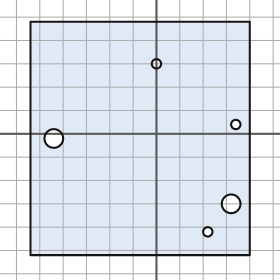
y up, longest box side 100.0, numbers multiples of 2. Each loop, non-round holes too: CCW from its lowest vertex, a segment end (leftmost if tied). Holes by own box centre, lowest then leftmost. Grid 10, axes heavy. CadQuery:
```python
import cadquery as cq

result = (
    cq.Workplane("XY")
    .moveTo(-54.0, -52.0)
    .lineTo(40.0, -52.0)
    .lineTo(40.0, 48.0)
    .lineTo(-54.0, 48.0)
    .close()
    .moveTo(22.0, -42.0)
    .circle(2.0)
    .moveTo(32.0, -30.0)
    .circle(4.0)
    .moveTo(-44.0, -2.0)
    .circle(4.0)
    .moveTo(34.0, 4.0)
    .circle(2.0)
    .moveTo(0.0, 30.0)
    .circle(2.0)
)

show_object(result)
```